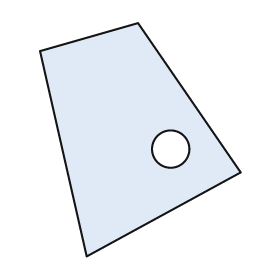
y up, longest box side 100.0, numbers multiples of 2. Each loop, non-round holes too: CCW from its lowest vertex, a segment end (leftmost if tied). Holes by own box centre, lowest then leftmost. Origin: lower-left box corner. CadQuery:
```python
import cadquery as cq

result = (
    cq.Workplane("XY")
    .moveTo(20.0, 0.0)
    .lineTo(86.0, 36.0)
    .lineTo(42.0, 100.0)
    .lineTo(0.0, 88.0)
    .close()
    .moveTo(56.0, 46.0)
    .circle(8.0)
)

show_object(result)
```